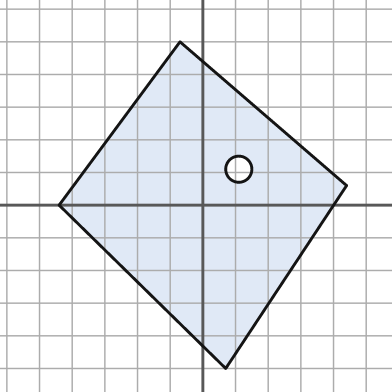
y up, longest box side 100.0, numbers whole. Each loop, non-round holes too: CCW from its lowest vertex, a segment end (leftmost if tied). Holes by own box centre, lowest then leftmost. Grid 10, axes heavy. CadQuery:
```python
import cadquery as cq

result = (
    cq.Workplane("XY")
    .moveTo(7.0, -50.0)
    .lineTo(44.0, 6.0)
    .lineTo(-7.0, 50.0)
    .lineTo(-44.0, 0.0)
    .close()
    .moveTo(11.0, 11.0)
    .circle(4.0)
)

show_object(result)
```